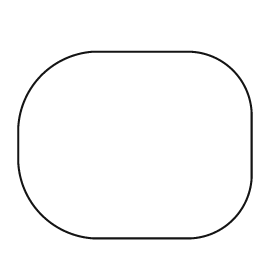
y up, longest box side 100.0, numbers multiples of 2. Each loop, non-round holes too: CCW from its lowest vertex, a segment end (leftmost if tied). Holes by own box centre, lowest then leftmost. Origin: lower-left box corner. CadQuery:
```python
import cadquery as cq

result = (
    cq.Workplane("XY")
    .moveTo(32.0, 0.0)
    .lineTo(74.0, 0.0)
    .threePointArc((92.0, 8.0), (100.0, 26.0))
    .lineTo(100.0, 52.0)
    .threePointArc((92.0, 72.0), (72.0, 80.0))
    .lineTo(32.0, 80.0)
    .threePointArc((10.0, 70.0), (0.0, 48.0))
    .lineTo(0.0, 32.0)
    .threePointArc((10.0, 10.0), (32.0, 0.0))
    .close()
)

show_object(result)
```